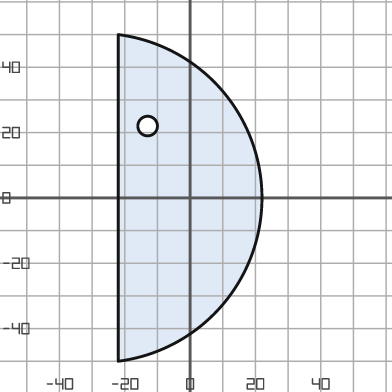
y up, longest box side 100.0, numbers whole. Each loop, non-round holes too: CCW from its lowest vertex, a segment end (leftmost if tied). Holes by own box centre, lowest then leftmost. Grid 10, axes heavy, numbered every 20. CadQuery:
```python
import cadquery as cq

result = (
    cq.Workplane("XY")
    .moveTo(-22.0, -50.0)
    .threePointArc((22.0, 0.0), (-22.0, 50.0))
    .close()
    .moveTo(-13.0, 22.0)
    .circle(3.0)
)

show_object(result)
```